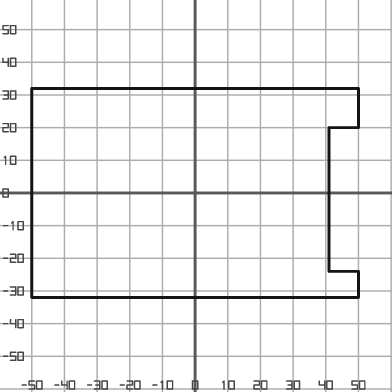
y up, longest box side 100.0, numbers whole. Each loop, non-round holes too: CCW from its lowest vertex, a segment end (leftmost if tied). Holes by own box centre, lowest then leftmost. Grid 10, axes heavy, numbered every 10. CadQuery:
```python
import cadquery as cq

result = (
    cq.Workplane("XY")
    .moveTo(-50.0, -32.0)
    .lineTo(50.0, -32.0)
    .lineTo(50.0, -24.0)
    .lineTo(41.0, -24.0)
    .lineTo(41.0, 20.0)
    .lineTo(50.0, 20.0)
    .lineTo(50.0, 32.0)
    .lineTo(-50.0, 32.0)
    .close()
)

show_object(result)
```